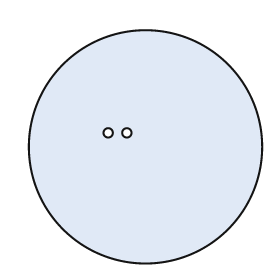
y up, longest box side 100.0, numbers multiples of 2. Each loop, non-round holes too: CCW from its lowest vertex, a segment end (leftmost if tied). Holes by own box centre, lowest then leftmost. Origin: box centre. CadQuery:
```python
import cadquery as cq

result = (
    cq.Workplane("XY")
    .moveTo(0.0, 0.0)
    .circle(50.0)
    .moveTo(-16.0, 6.0)
    .circle(2.0)
    .moveTo(-8.0, 6.0)
    .circle(2.0)
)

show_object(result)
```